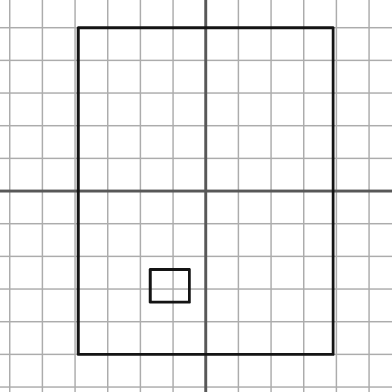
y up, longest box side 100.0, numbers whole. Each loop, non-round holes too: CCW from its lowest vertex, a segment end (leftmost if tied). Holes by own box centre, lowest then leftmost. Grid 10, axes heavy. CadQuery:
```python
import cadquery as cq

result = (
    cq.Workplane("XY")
    .moveTo(-39.0, -50.0)
    .lineTo(39.0, -50.0)
    .lineTo(39.0, 50.0)
    .lineTo(-39.0, 50.0)
    .close()
    .moveTo(-17.0, -34.0)
    .lineTo(-5.0, -34.0)
    .lineTo(-5.0, -24.0)
    .lineTo(-17.0, -24.0)
    .close()
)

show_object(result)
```